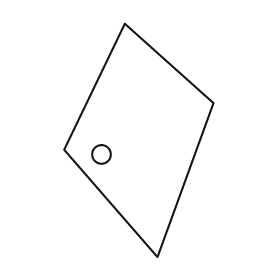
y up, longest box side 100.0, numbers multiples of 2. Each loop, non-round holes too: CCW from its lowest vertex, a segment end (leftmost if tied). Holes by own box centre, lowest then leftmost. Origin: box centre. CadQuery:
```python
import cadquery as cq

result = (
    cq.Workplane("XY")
    .moveTo(8.0, -50.0)
    .lineTo(32.0, 16.0)
    .lineTo(-6.0, 50.0)
    .lineTo(-32.0, -4.0)
    .close()
    .moveTo(-16.0, -6.0)
    .circle(4.0)
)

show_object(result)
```